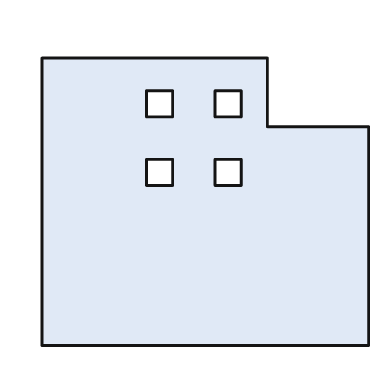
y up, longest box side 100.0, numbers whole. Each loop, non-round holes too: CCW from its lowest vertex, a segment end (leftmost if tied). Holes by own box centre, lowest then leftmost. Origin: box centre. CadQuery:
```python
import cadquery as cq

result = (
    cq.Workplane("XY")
    .moveTo(-50.0, -44.0)
    .lineTo(50.0, -44.0)
    .lineTo(50.0, 23.0)
    .lineTo(19.0, 23.0)
    .lineTo(19.0, 44.0)
    .lineTo(-50.0, 44.0)
    .close()
    .moveTo(-18.0, 5.0)
    .lineTo(-10.0, 5.0)
    .lineTo(-10.0, 13.0)
    .lineTo(-18.0, 13.0)
    .close()
    .moveTo(3.0, 5.0)
    .lineTo(11.0, 5.0)
    .lineTo(11.0, 13.0)
    .lineTo(3.0, 13.0)
    .close()
    .moveTo(-18.0, 26.0)
    .lineTo(-10.0, 26.0)
    .lineTo(-10.0, 34.0)
    .lineTo(-18.0, 34.0)
    .close()
    .moveTo(3.0, 26.0)
    .lineTo(11.0, 26.0)
    .lineTo(11.0, 34.0)
    .lineTo(3.0, 34.0)
    .close()
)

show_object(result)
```